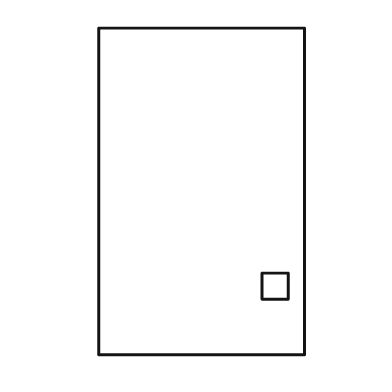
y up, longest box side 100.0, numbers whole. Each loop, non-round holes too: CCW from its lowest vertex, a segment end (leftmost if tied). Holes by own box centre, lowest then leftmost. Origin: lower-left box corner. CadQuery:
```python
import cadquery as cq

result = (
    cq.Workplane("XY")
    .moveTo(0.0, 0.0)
    .lineTo(63.0, 0.0)
    .lineTo(63.0, 100.0)
    .lineTo(0.0, 100.0)
    .close()
    .moveTo(50.0, 17.0)
    .lineTo(58.0, 17.0)
    .lineTo(58.0, 25.0)
    .lineTo(50.0, 25.0)
    .close()
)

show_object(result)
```